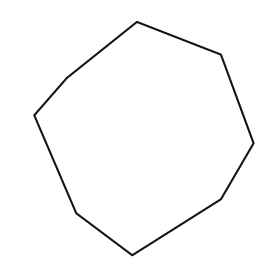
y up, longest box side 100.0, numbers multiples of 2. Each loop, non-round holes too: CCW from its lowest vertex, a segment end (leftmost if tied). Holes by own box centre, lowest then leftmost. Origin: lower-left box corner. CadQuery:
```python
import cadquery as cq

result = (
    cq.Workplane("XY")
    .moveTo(42.0, 0.0)
    .lineTo(80.0, 24.0)
    .lineTo(94.0, 48.0)
    .lineTo(80.0, 86.0)
    .lineTo(44.0, 100.0)
    .lineTo(14.0, 76.0)
    .lineTo(0.0, 60.0)
    .lineTo(18.0, 18.0)
    .close()
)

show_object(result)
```